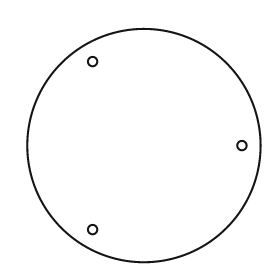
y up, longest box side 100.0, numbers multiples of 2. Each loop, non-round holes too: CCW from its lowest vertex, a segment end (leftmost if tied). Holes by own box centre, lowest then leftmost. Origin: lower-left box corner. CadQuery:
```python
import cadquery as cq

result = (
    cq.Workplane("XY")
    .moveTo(50.0, 50.0)
    .circle(50.0)
    .moveTo(28.0, 14.0)
    .circle(2.0)
    .moveTo(92.0, 50.0)
    .circle(2.0)
    .moveTo(28.0, 86.0)
    .circle(2.0)
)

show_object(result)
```